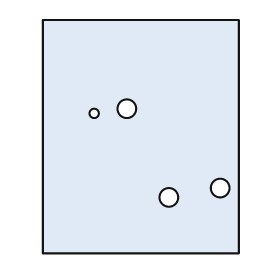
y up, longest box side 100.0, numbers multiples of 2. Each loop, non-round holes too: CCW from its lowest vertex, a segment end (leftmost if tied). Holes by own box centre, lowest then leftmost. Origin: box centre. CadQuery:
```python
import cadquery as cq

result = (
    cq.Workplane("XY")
    .moveTo(-42.0, -50.0)
    .lineTo(42.0, -50.0)
    .lineTo(42.0, 50.0)
    .lineTo(-42.0, 50.0)
    .close()
    .moveTo(12.0, -26.0)
    .circle(4.0)
    .moveTo(34.0, -22.0)
    .circle(4.0)
    .moveTo(-20.0, 10.0)
    .circle(2.0)
    .moveTo(-6.0, 12.0)
    .circle(4.0)
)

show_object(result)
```